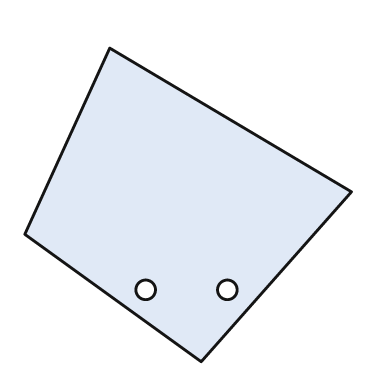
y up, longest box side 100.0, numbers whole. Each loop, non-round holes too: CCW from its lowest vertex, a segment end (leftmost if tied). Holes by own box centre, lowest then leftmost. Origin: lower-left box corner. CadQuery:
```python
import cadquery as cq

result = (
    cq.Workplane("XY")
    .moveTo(54.0, 0.0)
    .lineTo(100.0, 52.0)
    .lineTo(26.0, 96.0)
    .lineTo(0.0, 39.0)
    .close()
    .moveTo(37.0, 22.0)
    .circle(3.0)
    .moveTo(62.0, 22.0)
    .circle(3.0)
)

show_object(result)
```